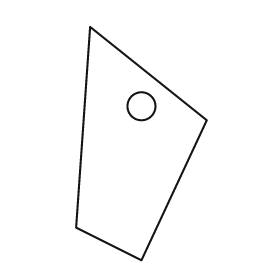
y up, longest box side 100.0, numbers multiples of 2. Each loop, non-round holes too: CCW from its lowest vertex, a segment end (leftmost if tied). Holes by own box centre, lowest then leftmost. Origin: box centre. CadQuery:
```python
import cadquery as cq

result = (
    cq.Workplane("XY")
    .moveTo(0.0, -50.0)
    .lineTo(28.0, 10.0)
    .lineTo(-22.0, 50.0)
    .lineTo(-28.0, -36.0)
    .close()
    .moveTo(0.0, 16.0)
    .circle(6.0)
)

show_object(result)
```